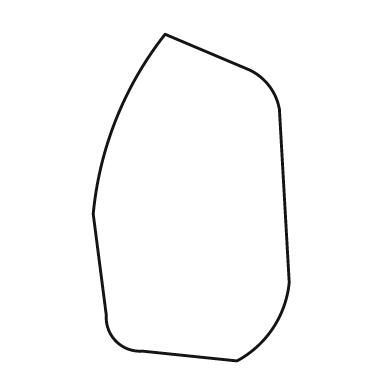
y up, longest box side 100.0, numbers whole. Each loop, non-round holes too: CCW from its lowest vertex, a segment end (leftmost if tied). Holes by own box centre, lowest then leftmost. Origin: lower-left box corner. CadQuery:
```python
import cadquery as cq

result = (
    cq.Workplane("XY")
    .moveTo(44.0, 0.0)
    .threePointArc((55.0, 10.0), (60.0, 24.0))
    .lineTo(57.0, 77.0)
    .threePointArc((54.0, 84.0), (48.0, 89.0))
    .lineTo(22.0, 100.0)
    .threePointArc((7.0, 74.0), (0.0, 45.0))
    .lineTo(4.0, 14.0)
    .threePointArc((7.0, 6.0), (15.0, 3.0))
    .close()
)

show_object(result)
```